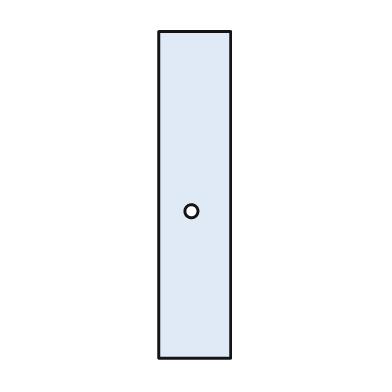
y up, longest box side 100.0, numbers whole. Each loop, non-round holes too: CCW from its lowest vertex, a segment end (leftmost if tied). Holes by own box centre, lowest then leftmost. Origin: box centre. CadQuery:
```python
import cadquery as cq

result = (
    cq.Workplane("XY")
    .moveTo(-11.0, -50.0)
    .lineTo(11.0, -50.0)
    .lineTo(11.0, 50.0)
    .lineTo(-11.0, 50.0)
    .close()
    .moveTo(-1.0, -5.0)
    .circle(2.0)
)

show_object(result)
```